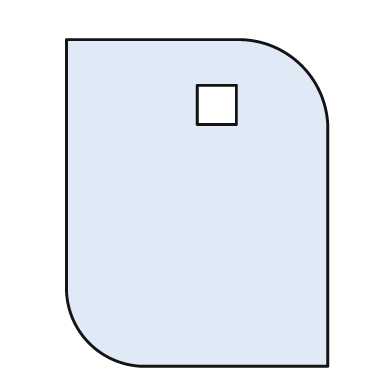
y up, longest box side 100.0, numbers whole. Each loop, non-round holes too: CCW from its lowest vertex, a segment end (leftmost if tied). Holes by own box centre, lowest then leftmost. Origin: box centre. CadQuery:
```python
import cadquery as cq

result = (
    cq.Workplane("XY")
    .moveTo(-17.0, -50.0)
    .lineTo(40.0, -50.0)
    .lineTo(40.0, 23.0)
    .threePointArc((32.0, 42.0), (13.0, 50.0))
    .lineTo(-40.0, 50.0)
    .lineTo(-40.0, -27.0)
    .threePointArc((-33.0, -43.0), (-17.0, -50.0))
    .close()
    .moveTo(0.0, 24.0)
    .lineTo(12.0, 24.0)
    .lineTo(12.0, 36.0)
    .lineTo(0.0, 36.0)
    .close()
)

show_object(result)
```